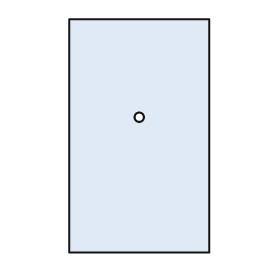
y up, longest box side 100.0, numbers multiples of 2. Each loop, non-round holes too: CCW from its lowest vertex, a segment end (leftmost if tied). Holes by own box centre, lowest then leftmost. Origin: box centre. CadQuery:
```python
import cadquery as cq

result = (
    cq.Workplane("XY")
    .moveTo(-30.0, -50.0)
    .lineTo(30.0, -50.0)
    .lineTo(30.0, 50.0)
    .lineTo(-30.0, 50.0)
    .close()
    .moveTo(0.0, 8.0)
    .circle(2.0)
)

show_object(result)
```